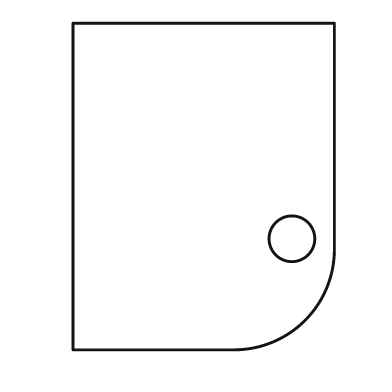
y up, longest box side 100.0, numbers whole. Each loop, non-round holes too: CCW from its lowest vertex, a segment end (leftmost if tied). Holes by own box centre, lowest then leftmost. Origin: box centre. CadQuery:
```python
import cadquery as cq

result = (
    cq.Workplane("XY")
    .moveTo(-40.0, -50.0)
    .lineTo(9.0, -50.0)
    .threePointArc((31.0, -41.0), (40.0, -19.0))
    .lineTo(40.0, 50.0)
    .lineTo(-40.0, 50.0)
    .close()
    .moveTo(27.0, -16.0)
    .circle(7.0)
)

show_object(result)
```